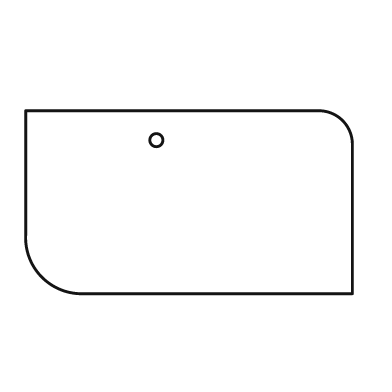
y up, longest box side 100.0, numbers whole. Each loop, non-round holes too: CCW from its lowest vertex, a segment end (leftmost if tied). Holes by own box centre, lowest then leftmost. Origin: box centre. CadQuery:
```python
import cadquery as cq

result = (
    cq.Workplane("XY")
    .moveTo(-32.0, -28.0)
    .lineTo(50.0, -28.0)
    .lineTo(50.0, 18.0)
    .threePointArc((47.0, 25.0), (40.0, 28.0))
    .lineTo(-50.0, 28.0)
    .lineTo(-50.0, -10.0)
    .threePointArc((-45.0, -23.0), (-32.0, -28.0))
    .close()
    .moveTo(-10.0, 19.0)
    .circle(2.0)
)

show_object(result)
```